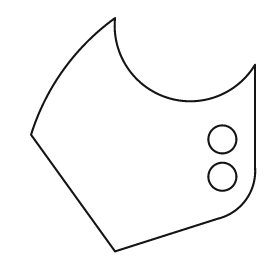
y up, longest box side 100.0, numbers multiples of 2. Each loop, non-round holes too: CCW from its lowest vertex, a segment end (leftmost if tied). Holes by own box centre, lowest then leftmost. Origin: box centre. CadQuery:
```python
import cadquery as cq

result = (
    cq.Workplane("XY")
    .moveTo(-12.0, -50.0)
    .lineTo(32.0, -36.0)
    .threePointArc((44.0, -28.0), (48.0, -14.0))
    .lineTo(48.0, 30.0)
    .threePointArc((10.0, 16.0), (-12.0, 50.0))
    .threePointArc((-34.0, 28.0), (-48.0, 0.0))
    .close()
    .moveTo(34.0, -18.0)
    .circle(6.0)
    .moveTo(34.0, -2.0)
    .circle(6.0)
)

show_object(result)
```